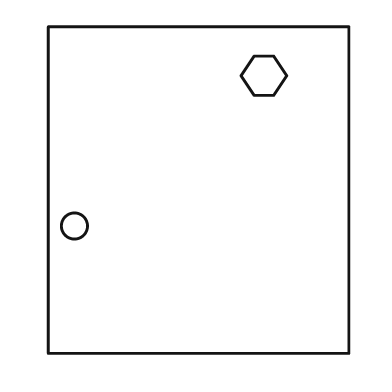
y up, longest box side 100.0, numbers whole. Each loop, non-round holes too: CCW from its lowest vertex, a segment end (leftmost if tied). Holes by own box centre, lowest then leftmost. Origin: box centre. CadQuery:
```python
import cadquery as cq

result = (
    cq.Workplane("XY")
    .moveTo(-46.0, -50.0)
    .lineTo(46.0, -50.0)
    .lineTo(46.0, 50.0)
    .lineTo(-46.0, 50.0)
    .close()
    .moveTo(-38.0, -11.0)
    .circle(4.0)
    .moveTo(17.0, 29.0)
    .lineTo(23.0, 29.0)
    .lineTo(27.0, 35.0)
    .lineTo(23.0, 41.0)
    .lineTo(17.0, 41.0)
    .lineTo(13.0, 35.0)
    .close()
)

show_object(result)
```